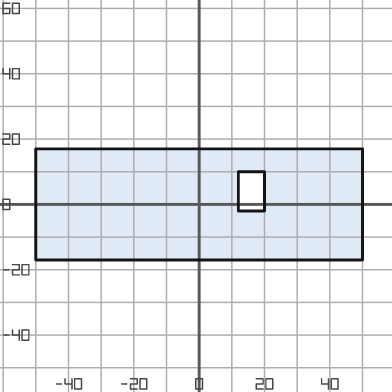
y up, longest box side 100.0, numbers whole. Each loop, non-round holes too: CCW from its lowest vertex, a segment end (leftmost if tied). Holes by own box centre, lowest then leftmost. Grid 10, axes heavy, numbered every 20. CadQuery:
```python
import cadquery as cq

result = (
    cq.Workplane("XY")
    .moveTo(-50.0, -17.0)
    .lineTo(50.0, -17.0)
    .lineTo(50.0, 17.0)
    .lineTo(-50.0, 17.0)
    .close()
    .moveTo(12.0, -2.0)
    .lineTo(20.0, -2.0)
    .lineTo(20.0, 10.0)
    .lineTo(12.0, 10.0)
    .close()
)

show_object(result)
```